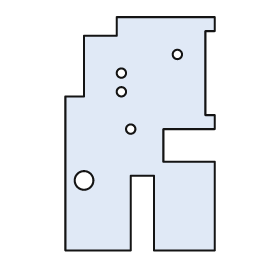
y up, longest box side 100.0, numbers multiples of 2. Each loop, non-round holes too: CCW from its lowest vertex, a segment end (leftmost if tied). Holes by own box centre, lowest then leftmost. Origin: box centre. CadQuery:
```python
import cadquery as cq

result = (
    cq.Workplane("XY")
    .moveTo(-32.0, -50.0)
    .lineTo(-4.0, -50.0)
    .lineTo(-4.0, -18.0)
    .lineTo(6.0, -18.0)
    .lineTo(6.0, -50.0)
    .lineTo(32.0, -50.0)
    .lineTo(32.0, -12.0)
    .lineTo(10.0, -12.0)
    .lineTo(10.0, 2.0)
    .lineTo(32.0, 2.0)
    .lineTo(32.0, 8.0)
    .lineTo(28.0, 8.0)
    .lineTo(28.0, 44.0)
    .lineTo(32.0, 44.0)
    .lineTo(32.0, 50.0)
    .lineTo(-10.0, 50.0)
    .lineTo(-10.0, 42.0)
    .lineTo(-24.0, 42.0)
    .lineTo(-24.0, 16.0)
    .lineTo(-32.0, 16.0)
    .close()
    .moveTo(-24.0, -20.0)
    .circle(4.0)
    .moveTo(-4.0, 2.0)
    .circle(2.0)
    .moveTo(-8.0, 18.0)
    .circle(2.0)
    .moveTo(-8.0, 26.0)
    .circle(2.0)
    .moveTo(16.0, 34.0)
    .circle(2.0)
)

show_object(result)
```